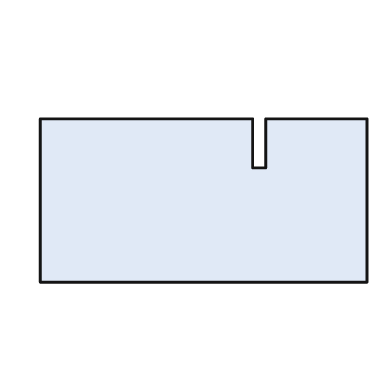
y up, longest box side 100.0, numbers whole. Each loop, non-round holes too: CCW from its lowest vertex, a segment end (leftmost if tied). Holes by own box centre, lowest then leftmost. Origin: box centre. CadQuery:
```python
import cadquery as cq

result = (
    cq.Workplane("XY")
    .moveTo(-50.0, -25.0)
    .lineTo(50.0, -25.0)
    .lineTo(50.0, 25.0)
    .lineTo(19.0, 25.0)
    .lineTo(19.0, 10.0)
    .lineTo(15.0, 10.0)
    .lineTo(15.0, 25.0)
    .lineTo(-50.0, 25.0)
    .close()
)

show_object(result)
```